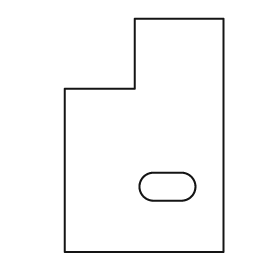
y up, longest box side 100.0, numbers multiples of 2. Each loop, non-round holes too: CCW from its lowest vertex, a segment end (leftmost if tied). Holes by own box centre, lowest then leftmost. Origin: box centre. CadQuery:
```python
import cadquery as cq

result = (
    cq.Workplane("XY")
    .moveTo(-34.0, -50.0)
    .lineTo(34.0, -50.0)
    .lineTo(34.0, 50.0)
    .lineTo(-4.0, 50.0)
    .lineTo(-4.0, 20.0)
    .lineTo(-34.0, 20.0)
    .close()
    .moveTo(4.0, -28.0)
    .lineTo(16.0, -28.0)
    .threePointArc((22.0, -22.0), (16.0, -16.0))
    .lineTo(4.0, -16.0)
    .threePointArc((-2.0, -22.0), (4.0, -28.0))
    .close()
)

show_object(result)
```